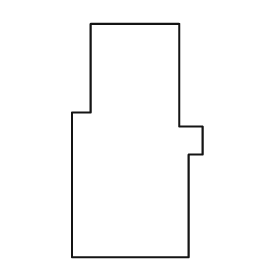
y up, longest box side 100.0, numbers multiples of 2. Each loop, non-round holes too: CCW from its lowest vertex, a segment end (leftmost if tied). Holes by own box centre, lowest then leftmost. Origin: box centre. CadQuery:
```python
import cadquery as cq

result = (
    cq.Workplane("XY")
    .moveTo(-28.0, -50.0)
    .lineTo(22.0, -50.0)
    .lineTo(22.0, -6.0)
    .lineTo(28.0, -6.0)
    .lineTo(28.0, 6.0)
    .lineTo(18.0, 6.0)
    .lineTo(18.0, 50.0)
    .lineTo(-20.0, 50.0)
    .lineTo(-20.0, 12.0)
    .lineTo(-28.0, 12.0)
    .close()
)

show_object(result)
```